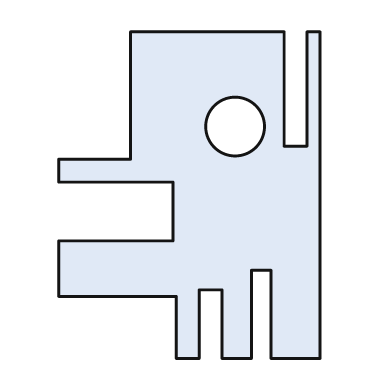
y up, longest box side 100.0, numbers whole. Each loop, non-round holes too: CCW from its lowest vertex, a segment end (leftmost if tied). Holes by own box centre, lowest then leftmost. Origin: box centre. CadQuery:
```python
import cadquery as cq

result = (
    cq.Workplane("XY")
    .moveTo(-4.0, -50.0)
    .lineTo(3.0, -50.0)
    .lineTo(3.0, -29.0)
    .lineTo(10.0, -29.0)
    .lineTo(10.0, -50.0)
    .lineTo(19.0, -50.0)
    .lineTo(19.0, -23.0)
    .lineTo(25.0, -23.0)
    .lineTo(25.0, -50.0)
    .lineTo(40.0, -50.0)
    .lineTo(40.0, 50.0)
    .lineTo(36.0, 50.0)
    .lineTo(36.0, 15.0)
    .lineTo(29.0, 15.0)
    .lineTo(29.0, 50.0)
    .lineTo(-18.0, 50.0)
    .lineTo(-18.0, 11.0)
    .lineTo(-40.0, 11.0)
    .lineTo(-40.0, 4.0)
    .lineTo(-5.0, 4.0)
    .lineTo(-5.0, -14.0)
    .lineTo(-40.0, -14.0)
    .lineTo(-40.0, -31.0)
    .lineTo(-4.0, -31.0)
    .close()
    .moveTo(14.0, 21.0)
    .circle(9.0)
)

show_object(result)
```